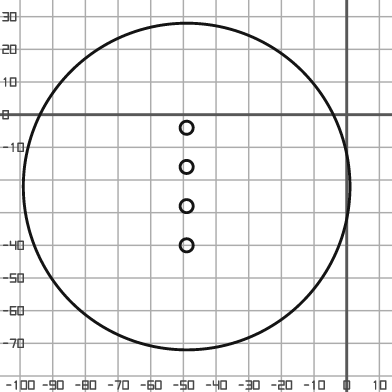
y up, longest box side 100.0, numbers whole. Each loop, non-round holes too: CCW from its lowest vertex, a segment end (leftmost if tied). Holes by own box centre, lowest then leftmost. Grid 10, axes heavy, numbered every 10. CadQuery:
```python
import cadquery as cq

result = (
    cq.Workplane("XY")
    .moveTo(-49.0, -22.0)
    .circle(50.0)
    .moveTo(-49.0, -40.0)
    .circle(2.0)
    .moveTo(-49.0, -28.0)
    .circle(2.0)
    .moveTo(-49.0, -16.0)
    .circle(2.0)
    .moveTo(-49.0, -4.0)
    .circle(2.0)
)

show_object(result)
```